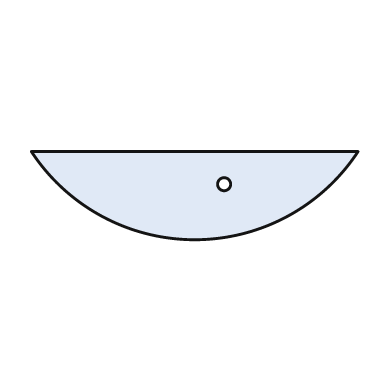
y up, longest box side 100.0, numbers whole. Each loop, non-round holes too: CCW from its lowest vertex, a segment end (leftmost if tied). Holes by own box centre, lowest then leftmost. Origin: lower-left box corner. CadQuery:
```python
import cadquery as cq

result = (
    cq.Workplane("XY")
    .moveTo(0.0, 27.0)
    .threePointArc((50.0, 0.0), (100.0, 27.0))
    .close()
    .moveTo(59.0, 17.0)
    .circle(2.0)
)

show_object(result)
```